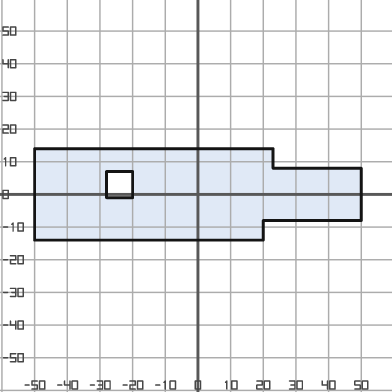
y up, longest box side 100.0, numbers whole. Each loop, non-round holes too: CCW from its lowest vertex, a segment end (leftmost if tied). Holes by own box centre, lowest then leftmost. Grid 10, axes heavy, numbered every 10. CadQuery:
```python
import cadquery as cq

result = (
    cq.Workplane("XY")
    .moveTo(-50.0, -14.0)
    .lineTo(20.0, -14.0)
    .lineTo(20.0, -8.0)
    .lineTo(50.0, -8.0)
    .lineTo(50.0, 8.0)
    .lineTo(23.0, 8.0)
    .lineTo(23.0, 14.0)
    .lineTo(-50.0, 14.0)
    .close()
    .moveTo(-28.0, -1.0)
    .lineTo(-20.0, -1.0)
    .lineTo(-20.0, 7.0)
    .lineTo(-28.0, 7.0)
    .close()
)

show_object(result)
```